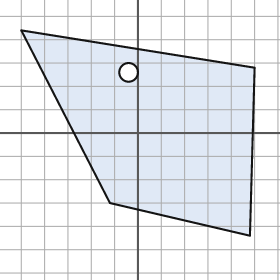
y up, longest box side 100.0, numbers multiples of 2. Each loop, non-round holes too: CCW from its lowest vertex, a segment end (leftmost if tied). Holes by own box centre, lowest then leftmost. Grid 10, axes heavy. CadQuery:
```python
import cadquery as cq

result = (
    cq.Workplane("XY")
    .moveTo(48.0, -44.0)
    .lineTo(50.0, 28.0)
    .lineTo(-50.0, 44.0)
    .lineTo(-12.0, -30.0)
    .close()
    .moveTo(-4.0, 26.0)
    .circle(4.0)
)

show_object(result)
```